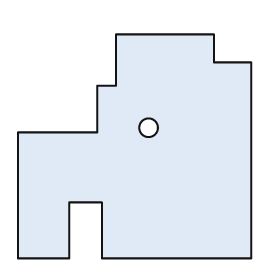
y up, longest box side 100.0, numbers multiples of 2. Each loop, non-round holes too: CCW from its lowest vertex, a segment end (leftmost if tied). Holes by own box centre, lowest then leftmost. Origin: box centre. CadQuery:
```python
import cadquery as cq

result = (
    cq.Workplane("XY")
    .moveTo(-50.0, -48.0)
    .lineTo(-28.0, -48.0)
    .lineTo(-28.0, -24.0)
    .lineTo(-14.0, -24.0)
    .lineTo(-14.0, -48.0)
    .lineTo(50.0, -48.0)
    .lineTo(50.0, 36.0)
    .lineTo(34.0, 36.0)
    .lineTo(34.0, 48.0)
    .lineTo(-8.0, 48.0)
    .lineTo(-8.0, 26.0)
    .lineTo(-16.0, 26.0)
    .lineTo(-16.0, 6.0)
    .lineTo(-50.0, 6.0)
    .close()
    .moveTo(6.0, 8.0)
    .circle(4.0)
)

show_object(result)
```